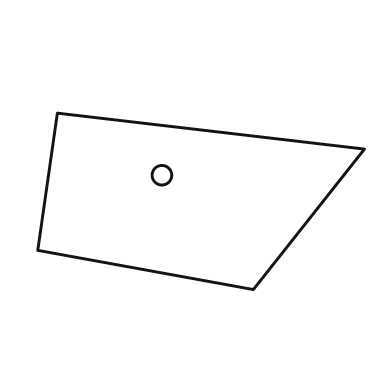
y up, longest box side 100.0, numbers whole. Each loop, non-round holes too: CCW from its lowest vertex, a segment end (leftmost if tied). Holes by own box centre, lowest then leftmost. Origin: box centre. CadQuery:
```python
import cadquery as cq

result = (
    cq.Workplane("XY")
    .moveTo(16.0, -27.0)
    .lineTo(50.0, 16.0)
    .lineTo(-44.0, 27.0)
    .lineTo(-50.0, -15.0)
    .close()
    .moveTo(-12.0, 8.0)
    .circle(3.0)
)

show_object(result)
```